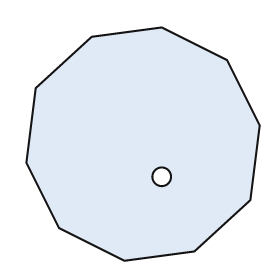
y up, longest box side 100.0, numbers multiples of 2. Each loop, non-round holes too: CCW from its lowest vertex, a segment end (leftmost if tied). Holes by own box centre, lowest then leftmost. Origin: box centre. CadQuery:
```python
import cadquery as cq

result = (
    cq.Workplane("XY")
    .moveTo(-8.0, -50.0)
    .lineTo(22.0, -46.0)
    .lineTo(46.0, -24.0)
    .lineTo(50.0, 8.0)
    .lineTo(36.0, 36.0)
    .lineTo(8.0, 50.0)
    .lineTo(-22.0, 46.0)
    .lineTo(-46.0, 24.0)
    .lineTo(-50.0, -8.0)
    .lineTo(-36.0, -36.0)
    .close()
    .moveTo(8.0, -14.0)
    .circle(4.0)
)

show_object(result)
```